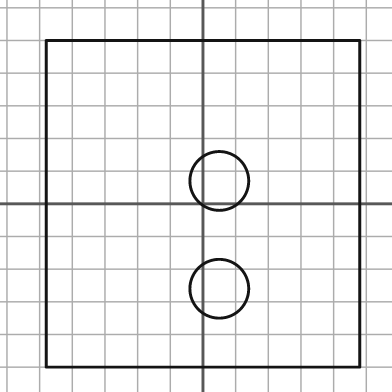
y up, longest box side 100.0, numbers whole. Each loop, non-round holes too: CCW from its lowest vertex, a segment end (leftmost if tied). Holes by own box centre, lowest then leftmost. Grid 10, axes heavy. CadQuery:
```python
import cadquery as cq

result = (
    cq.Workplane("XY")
    .moveTo(-48.0, -50.0)
    .lineTo(48.0, -50.0)
    .lineTo(48.0, 50.0)
    .lineTo(-48.0, 50.0)
    .close()
    .moveTo(5.0, -26.0)
    .circle(9.0)
    .moveTo(5.0, 7.0)
    .circle(9.0)
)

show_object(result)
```